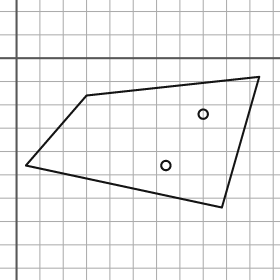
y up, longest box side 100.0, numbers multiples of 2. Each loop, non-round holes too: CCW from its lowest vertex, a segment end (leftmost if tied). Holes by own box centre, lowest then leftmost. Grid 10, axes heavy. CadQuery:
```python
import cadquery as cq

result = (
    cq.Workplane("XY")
    .moveTo(88.0, -64.0)
    .lineTo(104.0, -8.0)
    .lineTo(30.0, -16.0)
    .lineTo(4.0, -46.0)
    .close()
    .moveTo(64.0, -46.0)
    .circle(2.0)
    .moveTo(80.0, -24.0)
    .circle(2.0)
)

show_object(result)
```